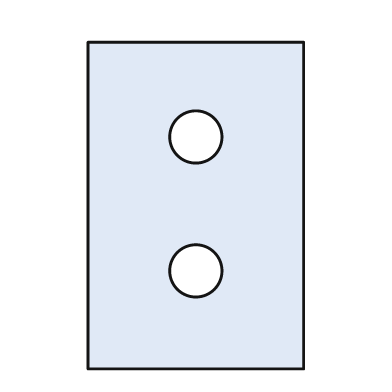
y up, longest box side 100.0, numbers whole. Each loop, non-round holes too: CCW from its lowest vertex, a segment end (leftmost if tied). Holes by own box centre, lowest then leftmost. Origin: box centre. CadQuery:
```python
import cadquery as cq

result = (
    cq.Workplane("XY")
    .moveTo(-33.0, -50.0)
    .lineTo(33.0, -50.0)
    .lineTo(33.0, 50.0)
    .lineTo(-33.0, 50.0)
    .close()
    .moveTo(0.0, -20.0)
    .circle(8.0)
    .moveTo(0.0, 21.0)
    .circle(8.0)
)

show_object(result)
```